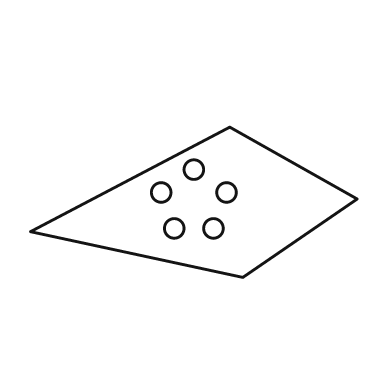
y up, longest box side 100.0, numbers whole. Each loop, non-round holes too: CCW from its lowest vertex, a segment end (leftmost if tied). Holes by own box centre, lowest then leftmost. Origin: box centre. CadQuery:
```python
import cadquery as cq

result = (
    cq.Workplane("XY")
    .moveTo(15.0, -23.0)
    .lineTo(50.0, 1.0)
    .lineTo(11.0, 23.0)
    .lineTo(-50.0, -9.0)
    .close()
    .moveTo(-6.0, -8.0)
    .circle(3.0)
    .moveTo(6.0, -8.0)
    .circle(3.0)
    .moveTo(-10.0, 3.0)
    .circle(3.0)
    .moveTo(10.0, 3.0)
    .circle(3.0)
    .moveTo(0.0, 10.0)
    .circle(3.0)
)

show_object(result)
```